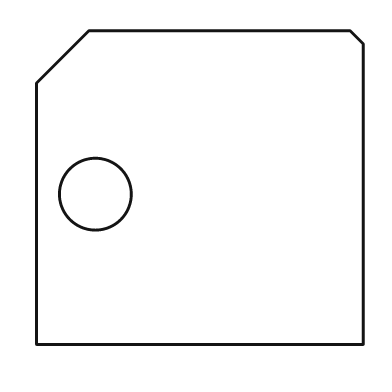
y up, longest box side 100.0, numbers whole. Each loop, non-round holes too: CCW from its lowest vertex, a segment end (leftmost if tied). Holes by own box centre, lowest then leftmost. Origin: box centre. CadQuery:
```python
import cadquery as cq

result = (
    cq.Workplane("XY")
    .moveTo(-50.0, -48.0)
    .lineTo(50.0, -48.0)
    .lineTo(50.0, 44.0)
    .lineTo(46.0, 48.0)
    .lineTo(-34.0, 48.0)
    .lineTo(-50.0, 32.0)
    .close()
    .moveTo(-32.0, -2.0)
    .circle(11.0)
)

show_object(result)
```